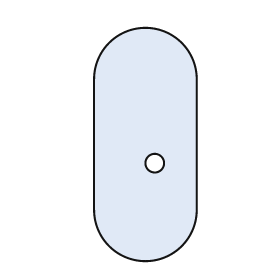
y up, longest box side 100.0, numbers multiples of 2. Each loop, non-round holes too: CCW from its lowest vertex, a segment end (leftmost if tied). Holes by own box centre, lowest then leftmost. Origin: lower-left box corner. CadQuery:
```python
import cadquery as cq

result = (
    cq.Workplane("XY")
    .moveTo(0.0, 22.0)
    .threePointArc((22.0, 0.0), (44.0, 22.0))
    .lineTo(44.0, 78.0)
    .threePointArc((22.0, 100.0), (0.0, 78.0))
    .close()
    .moveTo(26.0, 42.0)
    .circle(4.0)
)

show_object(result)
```